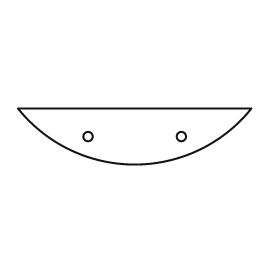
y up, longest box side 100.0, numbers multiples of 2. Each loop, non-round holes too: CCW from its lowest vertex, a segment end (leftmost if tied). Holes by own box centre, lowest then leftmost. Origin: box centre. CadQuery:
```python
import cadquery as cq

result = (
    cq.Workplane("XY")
    .moveTo(-50.0, 12.0)
    .threePointArc((0.0, -12.0), (50.0, 12.0))
    .close()
    .moveTo(-20.0, 0.0)
    .circle(2.0)
    .moveTo(20.0, 0.0)
    .circle(2.0)
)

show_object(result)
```